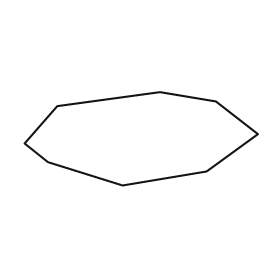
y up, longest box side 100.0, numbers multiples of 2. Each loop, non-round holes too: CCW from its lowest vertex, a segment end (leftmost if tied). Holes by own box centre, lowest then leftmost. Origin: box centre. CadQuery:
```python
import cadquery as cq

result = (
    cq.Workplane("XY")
    .moveTo(-8.0, -20.0)
    .lineTo(28.0, -14.0)
    .lineTo(50.0, 2.0)
    .lineTo(32.0, 16.0)
    .lineTo(8.0, 20.0)
    .lineTo(-36.0, 14.0)
    .lineTo(-50.0, -2.0)
    .lineTo(-40.0, -10.0)
    .close()
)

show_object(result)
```